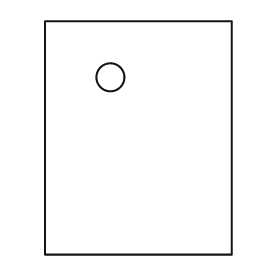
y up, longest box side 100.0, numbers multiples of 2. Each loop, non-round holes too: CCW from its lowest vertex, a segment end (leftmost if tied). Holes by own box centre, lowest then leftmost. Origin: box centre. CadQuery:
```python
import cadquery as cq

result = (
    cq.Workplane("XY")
    .moveTo(-40.0, -50.0)
    .lineTo(40.0, -50.0)
    .lineTo(40.0, 50.0)
    .lineTo(-40.0, 50.0)
    .close()
    .moveTo(-12.0, 26.0)
    .circle(6.0)
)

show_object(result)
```